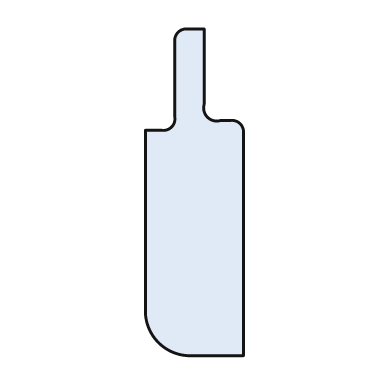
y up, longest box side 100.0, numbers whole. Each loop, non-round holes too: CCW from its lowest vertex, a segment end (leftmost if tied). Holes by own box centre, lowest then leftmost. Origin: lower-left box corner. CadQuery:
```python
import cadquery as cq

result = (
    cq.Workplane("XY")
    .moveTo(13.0, 0.0)
    .lineTo(30.0, 0.0)
    .lineTo(30.0, 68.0)
    .threePointArc((29.0, 71.0), (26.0, 72.0))
    .lineTo(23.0, 72.0)
    .threePointArc((19.0, 73.0), (18.0, 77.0))
    .lineTo(18.0, 100.0)
    .lineTo(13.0, 100.0)
    .threePointArc((10.0, 99.0), (9.0, 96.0))
    .lineTo(9.0, 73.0)
    .threePointArc((8.0, 70.0), (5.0, 69.0))
    .lineTo(0.0, 69.0)
    .lineTo(0.0, 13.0)
    .threePointArc((4.0, 4.0), (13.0, 0.0))
    .close()
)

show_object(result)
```